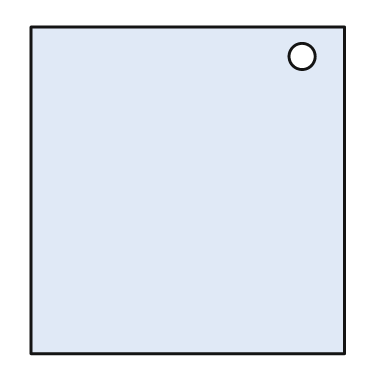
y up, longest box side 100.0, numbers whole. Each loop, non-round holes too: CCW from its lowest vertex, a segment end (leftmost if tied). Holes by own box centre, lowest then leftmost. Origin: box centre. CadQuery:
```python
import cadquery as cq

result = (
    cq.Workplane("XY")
    .moveTo(-48.0, -50.0)
    .lineTo(48.0, -50.0)
    .lineTo(48.0, 50.0)
    .lineTo(-48.0, 50.0)
    .close()
    .moveTo(35.0, 41.0)
    .circle(4.0)
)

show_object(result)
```